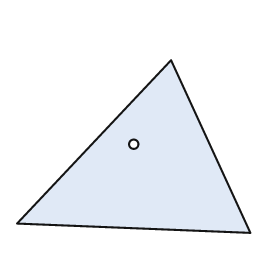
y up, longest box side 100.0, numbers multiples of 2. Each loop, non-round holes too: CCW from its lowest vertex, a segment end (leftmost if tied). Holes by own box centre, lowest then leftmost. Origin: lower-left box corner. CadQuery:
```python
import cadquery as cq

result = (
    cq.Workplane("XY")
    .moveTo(100.0, 0.0)
    .lineTo(66.0, 74.0)
    .lineTo(0.0, 4.0)
    .close()
    .moveTo(50.0, 38.0)
    .circle(2.0)
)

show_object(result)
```